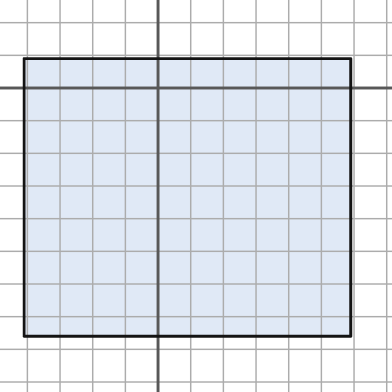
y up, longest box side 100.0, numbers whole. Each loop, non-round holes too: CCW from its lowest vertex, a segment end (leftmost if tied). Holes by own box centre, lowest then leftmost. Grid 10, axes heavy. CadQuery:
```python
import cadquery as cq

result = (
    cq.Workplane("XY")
    .moveTo(-41.0, -76.0)
    .lineTo(59.0, -76.0)
    .lineTo(59.0, 9.0)
    .lineTo(-41.0, 9.0)
    .close()
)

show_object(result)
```